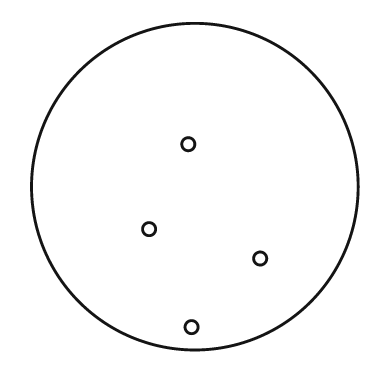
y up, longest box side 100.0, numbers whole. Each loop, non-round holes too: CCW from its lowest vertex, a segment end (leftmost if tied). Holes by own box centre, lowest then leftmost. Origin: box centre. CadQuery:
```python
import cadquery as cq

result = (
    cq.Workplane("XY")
    .moveTo(0.0, 0.0)
    .circle(50.0)
    .moveTo(-1.0, -43.0)
    .circle(2.0)
    .moveTo(20.0, -22.0)
    .circle(2.0)
    .moveTo(-14.0, -13.0)
    .circle(2.0)
    .moveTo(-2.0, 13.0)
    .circle(2.0)
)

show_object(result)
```